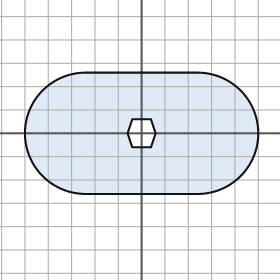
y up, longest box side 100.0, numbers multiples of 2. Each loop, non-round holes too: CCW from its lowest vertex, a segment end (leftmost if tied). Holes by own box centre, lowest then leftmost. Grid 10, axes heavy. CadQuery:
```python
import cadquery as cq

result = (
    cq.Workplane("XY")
    .moveTo(-24.0, -26.0)
    .lineTo(24.0, -26.0)
    .threePointArc((50.0, 0.0), (24.0, 26.0))
    .lineTo(-24.0, 26.0)
    .threePointArc((-50.0, 0.0), (-24.0, -26.0))
    .close()
    .moveTo(-4.0, -6.0)
    .lineTo(4.0, -6.0)
    .lineTo(6.0, 0.0)
    .lineTo(4.0, 6.0)
    .lineTo(-4.0, 6.0)
    .lineTo(-6.0, 0.0)
    .close()
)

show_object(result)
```